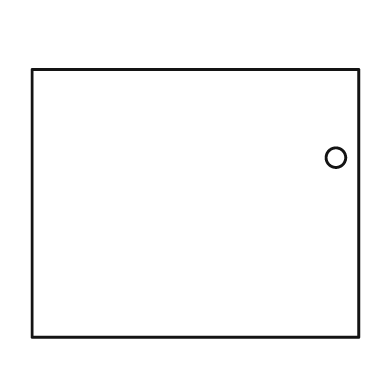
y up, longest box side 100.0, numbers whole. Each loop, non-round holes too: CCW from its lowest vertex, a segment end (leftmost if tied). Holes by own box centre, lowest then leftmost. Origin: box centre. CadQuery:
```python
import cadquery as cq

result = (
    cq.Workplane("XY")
    .moveTo(-50.0, -41.0)
    .lineTo(50.0, -41.0)
    .lineTo(50.0, 41.0)
    .lineTo(-50.0, 41.0)
    .close()
    .moveTo(43.0, 14.0)
    .circle(3.0)
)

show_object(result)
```